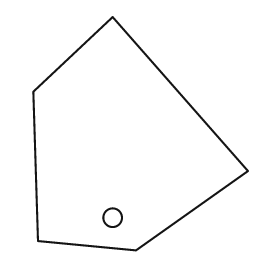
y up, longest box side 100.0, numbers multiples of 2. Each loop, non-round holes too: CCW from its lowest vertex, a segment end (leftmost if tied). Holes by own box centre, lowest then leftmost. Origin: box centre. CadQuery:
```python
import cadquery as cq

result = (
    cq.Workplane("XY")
    .moveTo(-2.0, -50.0)
    .lineTo(46.0, -16.0)
    .lineTo(-12.0, 50.0)
    .lineTo(-46.0, 18.0)
    .lineTo(-44.0, -46.0)
    .close()
    .moveTo(-12.0, -36.0)
    .circle(4.0)
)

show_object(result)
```